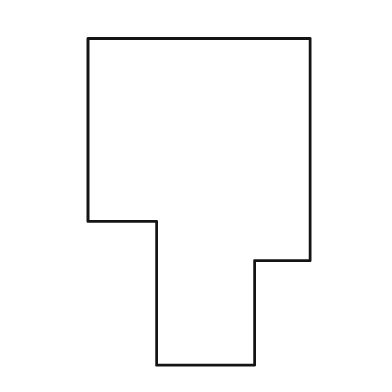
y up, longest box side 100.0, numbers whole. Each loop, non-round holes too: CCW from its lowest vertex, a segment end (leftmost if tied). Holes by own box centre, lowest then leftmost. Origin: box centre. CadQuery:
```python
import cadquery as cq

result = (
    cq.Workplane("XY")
    .moveTo(-13.0, -50.0)
    .lineTo(17.0, -50.0)
    .lineTo(17.0, -18.0)
    .lineTo(34.0, -18.0)
    .lineTo(34.0, 50.0)
    .lineTo(-34.0, 50.0)
    .lineTo(-34.0, -6.0)
    .lineTo(-13.0, -6.0)
    .close()
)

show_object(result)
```